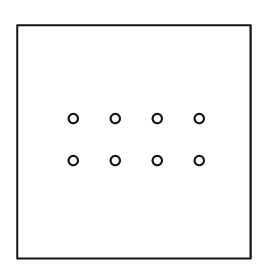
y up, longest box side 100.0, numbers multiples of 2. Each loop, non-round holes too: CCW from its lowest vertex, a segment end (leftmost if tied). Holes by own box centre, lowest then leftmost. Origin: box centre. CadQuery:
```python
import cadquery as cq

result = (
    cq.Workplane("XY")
    .moveTo(-50.0, -50.0)
    .lineTo(50.0, -50.0)
    .lineTo(50.0, 50.0)
    .lineTo(-50.0, 50.0)
    .close()
    .moveTo(-26.0, -8.0)
    .circle(2.0)
    .moveTo(-8.0, -8.0)
    .circle(2.0)
    .moveTo(10.0, -8.0)
    .circle(2.0)
    .moveTo(28.0, -8.0)
    .circle(2.0)
    .moveTo(-26.0, 10.0)
    .circle(2.0)
    .moveTo(-8.0, 10.0)
    .circle(2.0)
    .moveTo(10.0, 10.0)
    .circle(2.0)
    .moveTo(28.0, 10.0)
    .circle(2.0)
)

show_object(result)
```